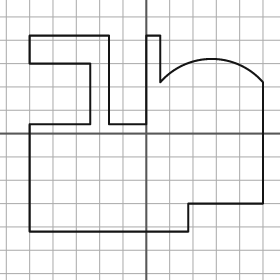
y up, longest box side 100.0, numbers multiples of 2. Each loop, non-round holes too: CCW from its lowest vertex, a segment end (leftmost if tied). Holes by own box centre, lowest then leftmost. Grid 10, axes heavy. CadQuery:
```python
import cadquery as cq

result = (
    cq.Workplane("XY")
    .moveTo(-50.0, -42.0)
    .lineTo(18.0, -42.0)
    .lineTo(18.0, -30.0)
    .lineTo(50.0, -30.0)
    .lineTo(50.0, 22.0)
    .threePointArc((28.0, 32.0), (6.0, 22.0))
    .lineTo(6.0, 42.0)
    .lineTo(0.0, 42.0)
    .lineTo(0.0, 4.0)
    .lineTo(-16.0, 4.0)
    .lineTo(-16.0, 42.0)
    .lineTo(-50.0, 42.0)
    .lineTo(-50.0, 30.0)
    .lineTo(-24.0, 30.0)
    .lineTo(-24.0, 4.0)
    .lineTo(-50.0, 4.0)
    .close()
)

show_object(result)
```